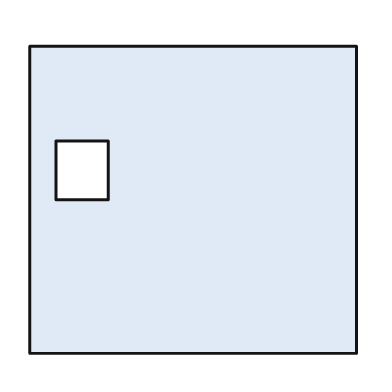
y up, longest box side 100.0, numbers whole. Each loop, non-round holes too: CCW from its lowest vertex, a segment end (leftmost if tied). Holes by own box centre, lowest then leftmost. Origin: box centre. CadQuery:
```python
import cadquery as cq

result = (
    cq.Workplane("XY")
    .moveTo(-50.0, -47.0)
    .lineTo(50.0, -47.0)
    .lineTo(50.0, 47.0)
    .lineTo(-50.0, 47.0)
    .close()
    .moveTo(-42.0, 0.0)
    .lineTo(-26.0, 0.0)
    .lineTo(-26.0, 18.0)
    .lineTo(-42.0, 18.0)
    .close()
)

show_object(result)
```